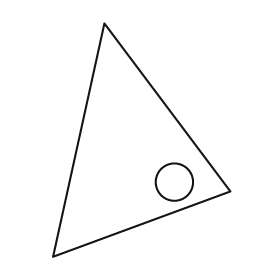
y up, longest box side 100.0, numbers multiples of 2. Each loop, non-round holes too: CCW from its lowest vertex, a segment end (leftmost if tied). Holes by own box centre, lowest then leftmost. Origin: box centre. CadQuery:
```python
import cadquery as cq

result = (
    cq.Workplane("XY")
    .moveTo(-38.0, -50.0)
    .lineTo(38.0, -22.0)
    .lineTo(-16.0, 50.0)
    .close()
    .moveTo(14.0, -18.0)
    .circle(8.0)
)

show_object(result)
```